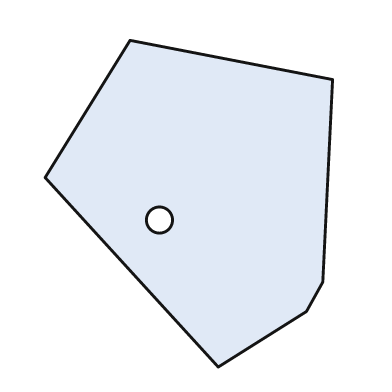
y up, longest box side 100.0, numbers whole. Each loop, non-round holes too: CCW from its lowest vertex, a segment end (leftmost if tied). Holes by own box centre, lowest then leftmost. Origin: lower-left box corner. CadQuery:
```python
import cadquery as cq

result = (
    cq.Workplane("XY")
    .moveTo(53.0, 0.0)
    .lineTo(80.0, 17.0)
    .lineTo(85.0, 26.0)
    .lineTo(88.0, 88.0)
    .lineTo(26.0, 100.0)
    .lineTo(0.0, 58.0)
    .close()
    .moveTo(35.0, 45.0)
    .circle(4.0)
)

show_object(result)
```